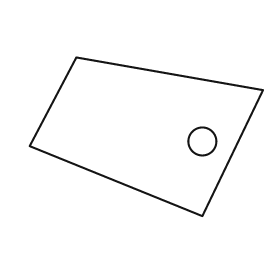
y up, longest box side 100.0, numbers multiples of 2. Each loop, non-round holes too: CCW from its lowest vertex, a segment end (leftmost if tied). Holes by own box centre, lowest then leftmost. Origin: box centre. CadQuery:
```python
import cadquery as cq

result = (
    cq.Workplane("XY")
    .moveTo(24.0, -34.0)
    .lineTo(50.0, 20.0)
    .lineTo(-30.0, 34.0)
    .lineTo(-50.0, -4.0)
    .close()
    .moveTo(24.0, -2.0)
    .circle(6.0)
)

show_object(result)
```